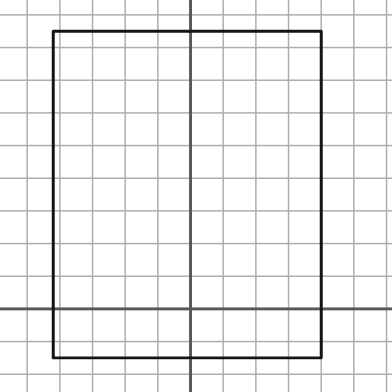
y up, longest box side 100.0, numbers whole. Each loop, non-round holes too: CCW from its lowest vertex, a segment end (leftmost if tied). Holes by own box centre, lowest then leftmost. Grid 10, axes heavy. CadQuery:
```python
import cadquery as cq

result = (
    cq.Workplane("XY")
    .moveTo(-42.0, -15.0)
    .lineTo(40.0, -15.0)
    .lineTo(40.0, 85.0)
    .lineTo(-42.0, 85.0)
    .close()
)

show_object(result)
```